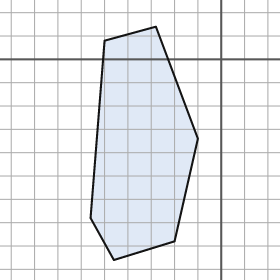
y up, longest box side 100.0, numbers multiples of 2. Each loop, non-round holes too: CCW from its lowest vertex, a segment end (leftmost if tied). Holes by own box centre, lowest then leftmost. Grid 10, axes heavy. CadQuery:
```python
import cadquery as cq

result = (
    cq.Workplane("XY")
    .moveTo(-46.0, -86.0)
    .lineTo(-20.0, -78.0)
    .lineTo(-10.0, -34.0)
    .lineTo(-28.0, 14.0)
    .lineTo(-50.0, 8.0)
    .lineTo(-56.0, -68.0)
    .close()
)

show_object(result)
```